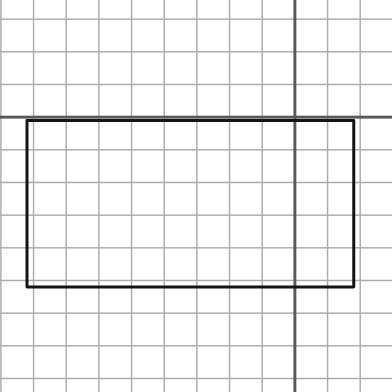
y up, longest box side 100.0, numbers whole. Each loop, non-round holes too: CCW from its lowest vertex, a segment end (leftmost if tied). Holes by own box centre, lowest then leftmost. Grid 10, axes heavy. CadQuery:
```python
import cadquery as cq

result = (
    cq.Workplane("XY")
    .moveTo(-82.0, -52.0)
    .lineTo(18.0, -52.0)
    .lineTo(18.0, -1.0)
    .lineTo(-82.0, -1.0)
    .close()
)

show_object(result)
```